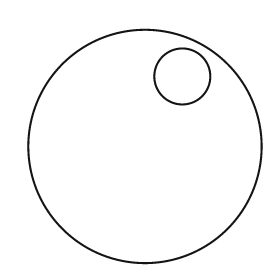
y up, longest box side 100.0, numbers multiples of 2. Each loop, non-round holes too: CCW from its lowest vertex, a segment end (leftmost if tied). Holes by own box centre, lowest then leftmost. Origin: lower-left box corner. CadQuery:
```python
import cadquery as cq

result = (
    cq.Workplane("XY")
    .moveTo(50.0, 50.0)
    .circle(50.0)
    .moveTo(66.0, 80.0)
    .circle(12.0)
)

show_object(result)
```